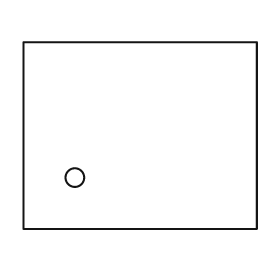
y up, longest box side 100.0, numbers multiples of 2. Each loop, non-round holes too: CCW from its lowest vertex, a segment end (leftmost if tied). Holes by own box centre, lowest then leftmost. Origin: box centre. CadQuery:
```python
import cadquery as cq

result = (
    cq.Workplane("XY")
    .moveTo(-50.0, -40.0)
    .lineTo(50.0, -40.0)
    .lineTo(50.0, 40.0)
    .lineTo(-50.0, 40.0)
    .close()
    .moveTo(-28.0, -18.0)
    .circle(4.0)
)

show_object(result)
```